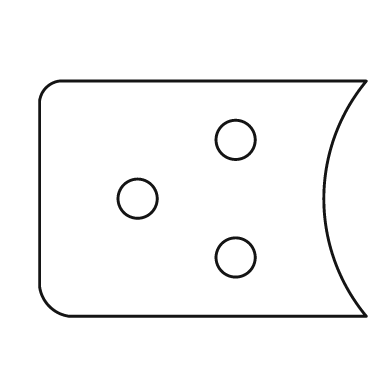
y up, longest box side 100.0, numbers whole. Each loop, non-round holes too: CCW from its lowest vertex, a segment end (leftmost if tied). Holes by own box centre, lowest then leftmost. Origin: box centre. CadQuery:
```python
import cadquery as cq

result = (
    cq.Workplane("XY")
    .moveTo(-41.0, -36.0)
    .lineTo(50.0, -36.0)
    .threePointArc((37.0, 0.0), (50.0, 36.0))
    .lineTo(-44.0, 36.0)
    .threePointArc((-48.0, 34.0), (-50.0, 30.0))
    .lineTo(-50.0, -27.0)
    .threePointArc((-47.0, -33.0), (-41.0, -36.0))
    .close()
    .moveTo(10.0, -18.0)
    .circle(6.0)
    .moveTo(-20.0, 0.0)
    .circle(6.0)
    .moveTo(10.0, 18.0)
    .circle(6.0)
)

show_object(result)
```